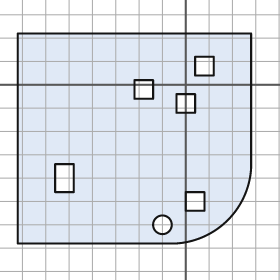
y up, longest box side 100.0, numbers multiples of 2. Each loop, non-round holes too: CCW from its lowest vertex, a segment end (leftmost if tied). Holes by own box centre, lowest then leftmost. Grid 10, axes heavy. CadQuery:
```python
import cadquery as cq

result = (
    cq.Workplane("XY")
    .moveTo(-72.0, -68.0)
    .lineTo(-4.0, -68.0)
    .threePointArc((18.0, -58.0), (28.0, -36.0))
    .lineTo(28.0, 22.0)
    .lineTo(-72.0, 22.0)
    .close()
    .moveTo(-10.0, -60.0)
    .circle(4.0)
    .moveTo(0.0, -54.0)
    .lineTo(8.0, -54.0)
    .lineTo(8.0, -46.0)
    .lineTo(0.0, -46.0)
    .close()
    .moveTo(-56.0, -46.0)
    .lineTo(-48.0, -46.0)
    .lineTo(-48.0, -34.0)
    .lineTo(-56.0, -34.0)
    .close()
    .moveTo(-4.0, -12.0)
    .lineTo(4.0, -12.0)
    .lineTo(4.0, -4.0)
    .lineTo(-4.0, -4.0)
    .close()
    .moveTo(-22.0, -6.0)
    .lineTo(-14.0, -6.0)
    .lineTo(-14.0, 2.0)
    .lineTo(-22.0, 2.0)
    .close()
    .moveTo(4.0, 4.0)
    .lineTo(12.0, 4.0)
    .lineTo(12.0, 12.0)
    .lineTo(4.0, 12.0)
    .close()
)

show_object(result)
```